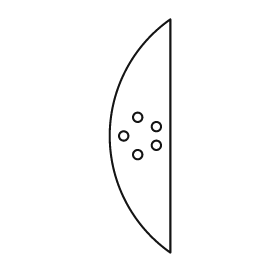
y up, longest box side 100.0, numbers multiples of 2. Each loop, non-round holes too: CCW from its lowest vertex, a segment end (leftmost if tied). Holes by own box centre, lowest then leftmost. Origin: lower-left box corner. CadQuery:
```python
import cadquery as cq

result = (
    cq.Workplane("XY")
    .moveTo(26.0, 0.0)
    .lineTo(26.0, 100.0)
    .threePointArc((0.0, 50.0), (26.0, 0.0))
    .close()
    .moveTo(12.0, 42.0)
    .circle(2.0)
    .moveTo(20.0, 46.0)
    .circle(2.0)
    .moveTo(6.0, 50.0)
    .circle(2.0)
    .moveTo(20.0, 54.0)
    .circle(2.0)
    .moveTo(12.0, 58.0)
    .circle(2.0)
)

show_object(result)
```